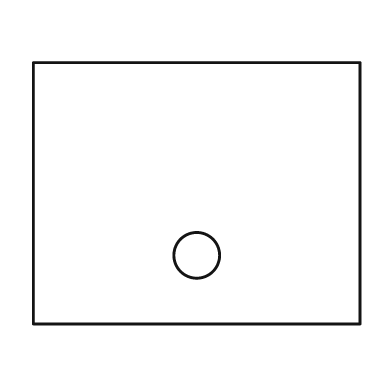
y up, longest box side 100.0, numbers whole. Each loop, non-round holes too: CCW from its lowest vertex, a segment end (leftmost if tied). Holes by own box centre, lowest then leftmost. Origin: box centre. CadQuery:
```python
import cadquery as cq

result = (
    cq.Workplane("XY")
    .moveTo(-50.0, -40.0)
    .lineTo(50.0, -40.0)
    .lineTo(50.0, 40.0)
    .lineTo(-50.0, 40.0)
    .close()
    .moveTo(0.0, -19.0)
    .circle(7.0)
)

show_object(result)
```